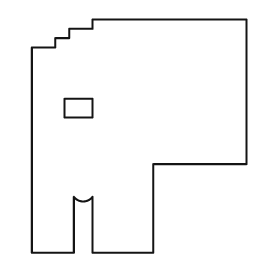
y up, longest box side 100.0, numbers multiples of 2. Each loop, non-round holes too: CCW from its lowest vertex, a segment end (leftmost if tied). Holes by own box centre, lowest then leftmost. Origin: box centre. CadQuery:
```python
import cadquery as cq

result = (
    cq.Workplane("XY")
    .moveTo(-46.0, -50.0)
    .lineTo(-28.0, -50.0)
    .lineTo(-28.0, -26.0)
    .threePointArc((-24.0, -28.0), (-20.0, -26.0))
    .lineTo(-20.0, -50.0)
    .lineTo(6.0, -50.0)
    .lineTo(6.0, -12.0)
    .lineTo(46.0, -12.0)
    .lineTo(46.0, 50.0)
    .lineTo(-20.0, 50.0)
    .lineTo(-20.0, 46.0)
    .lineTo(-30.0, 46.0)
    .lineTo(-30.0, 42.0)
    .lineTo(-36.0, 42.0)
    .lineTo(-36.0, 38.0)
    .lineTo(-46.0, 38.0)
    .close()
    .moveTo(-32.0, 8.0)
    .lineTo(-20.0, 8.0)
    .lineTo(-20.0, 16.0)
    .lineTo(-32.0, 16.0)
    .close()
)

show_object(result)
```